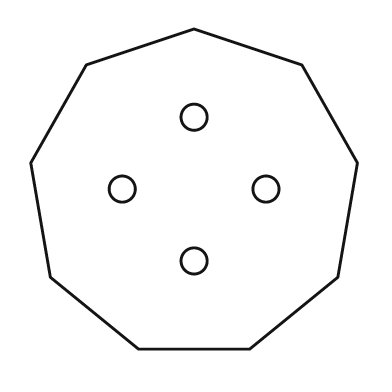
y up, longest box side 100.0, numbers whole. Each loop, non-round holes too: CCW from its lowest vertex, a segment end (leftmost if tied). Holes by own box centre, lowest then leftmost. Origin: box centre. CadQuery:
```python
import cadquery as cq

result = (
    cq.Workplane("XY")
    .moveTo(-17.0, -49.0)
    .lineTo(17.0, -49.0)
    .lineTo(44.0, -27.0)
    .lineTo(50.0, 8.0)
    .lineTo(33.0, 38.0)
    .lineTo(0.0, 49.0)
    .lineTo(-33.0, 38.0)
    .lineTo(-50.0, 8.0)
    .lineTo(-44.0, -27.0)
    .close()
    .moveTo(0.0, -22.0)
    .circle(4.0)
    .moveTo(-22.0, 0.0)
    .circle(4.0)
    .moveTo(22.0, 0.0)
    .circle(4.0)
    .moveTo(0.0, 22.0)
    .circle(4.0)
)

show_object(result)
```